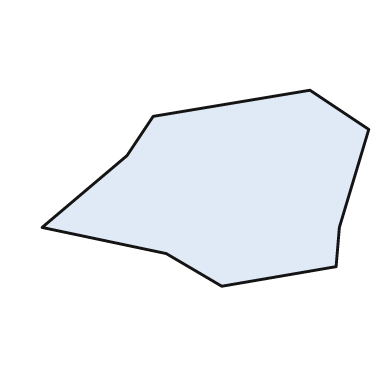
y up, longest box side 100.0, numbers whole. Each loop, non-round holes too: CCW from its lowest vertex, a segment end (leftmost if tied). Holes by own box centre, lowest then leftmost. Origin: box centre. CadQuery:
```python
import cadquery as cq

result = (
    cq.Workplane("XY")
    .moveTo(5.0, -30.0)
    .lineTo(40.0, -24.0)
    .lineTo(41.0, -12.0)
    .lineTo(50.0, 18.0)
    .lineTo(32.0, 30.0)
    .lineTo(-16.0, 22.0)
    .lineTo(-24.0, 10.0)
    .lineTo(-50.0, -12.0)
    .lineTo(-12.0, -20.0)
    .close()
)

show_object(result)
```